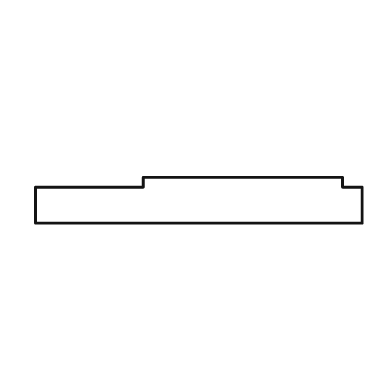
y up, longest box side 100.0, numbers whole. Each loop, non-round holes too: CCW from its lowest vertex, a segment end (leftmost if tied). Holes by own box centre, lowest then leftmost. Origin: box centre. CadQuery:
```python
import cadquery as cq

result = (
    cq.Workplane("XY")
    .moveTo(-50.0, -7.0)
    .lineTo(50.0, -7.0)
    .lineTo(50.0, 4.0)
    .lineTo(44.0, 4.0)
    .lineTo(44.0, 7.0)
    .lineTo(-17.0, 7.0)
    .lineTo(-17.0, 4.0)
    .lineTo(-50.0, 4.0)
    .close()
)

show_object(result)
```